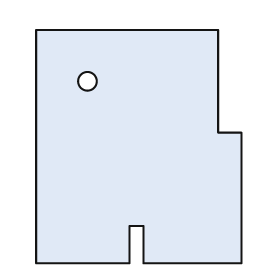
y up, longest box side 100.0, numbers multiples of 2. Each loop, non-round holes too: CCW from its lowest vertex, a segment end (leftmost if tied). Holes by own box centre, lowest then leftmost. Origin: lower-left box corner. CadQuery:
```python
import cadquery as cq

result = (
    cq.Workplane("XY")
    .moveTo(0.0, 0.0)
    .lineTo(40.0, 0.0)
    .lineTo(40.0, 16.0)
    .lineTo(46.0, 16.0)
    .lineTo(46.0, 0.0)
    .lineTo(88.0, 0.0)
    .lineTo(88.0, 56.0)
    .lineTo(78.0, 56.0)
    .lineTo(78.0, 100.0)
    .lineTo(0.0, 100.0)
    .close()
    .moveTo(22.0, 78.0)
    .circle(4.0)
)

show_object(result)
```